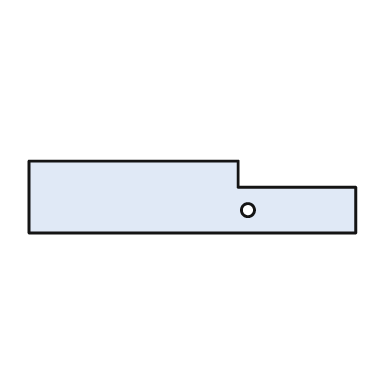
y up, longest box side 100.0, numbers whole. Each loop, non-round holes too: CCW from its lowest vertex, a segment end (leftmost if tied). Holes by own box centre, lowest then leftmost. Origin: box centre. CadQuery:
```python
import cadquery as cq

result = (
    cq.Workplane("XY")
    .moveTo(-50.0, -11.0)
    .lineTo(50.0, -11.0)
    .lineTo(50.0, 3.0)
    .lineTo(14.0, 3.0)
    .lineTo(14.0, 11.0)
    .lineTo(-50.0, 11.0)
    .close()
    .moveTo(17.0, -4.0)
    .circle(2.0)
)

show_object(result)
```